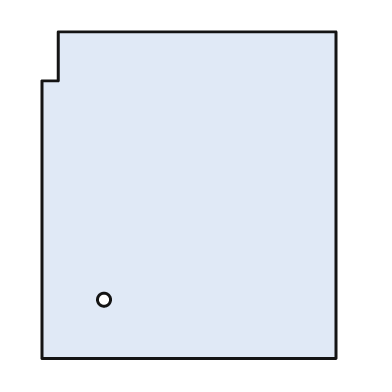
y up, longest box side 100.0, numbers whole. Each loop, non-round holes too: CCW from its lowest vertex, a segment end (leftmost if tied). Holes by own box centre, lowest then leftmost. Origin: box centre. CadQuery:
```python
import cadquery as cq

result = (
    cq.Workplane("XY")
    .moveTo(-45.0, -50.0)
    .lineTo(45.0, -50.0)
    .lineTo(45.0, 50.0)
    .lineTo(-40.0, 50.0)
    .lineTo(-40.0, 35.0)
    .lineTo(-45.0, 35.0)
    .close()
    .moveTo(-26.0, -32.0)
    .circle(2.0)
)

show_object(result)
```